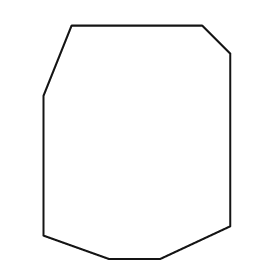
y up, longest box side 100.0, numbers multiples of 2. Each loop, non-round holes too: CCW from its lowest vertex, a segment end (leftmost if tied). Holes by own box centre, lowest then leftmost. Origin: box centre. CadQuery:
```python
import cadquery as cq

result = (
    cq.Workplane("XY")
    .moveTo(-12.0, -50.0)
    .lineTo(10.0, -50.0)
    .lineTo(40.0, -36.0)
    .lineTo(40.0, 38.0)
    .lineTo(28.0, 50.0)
    .lineTo(-28.0, 50.0)
    .lineTo(-40.0, 20.0)
    .lineTo(-40.0, -40.0)
    .close()
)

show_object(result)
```